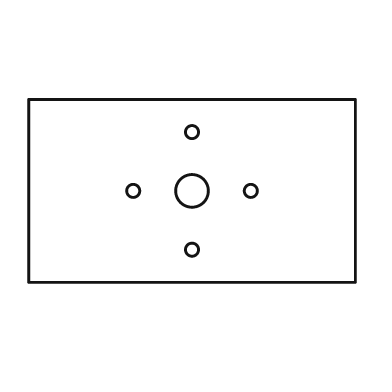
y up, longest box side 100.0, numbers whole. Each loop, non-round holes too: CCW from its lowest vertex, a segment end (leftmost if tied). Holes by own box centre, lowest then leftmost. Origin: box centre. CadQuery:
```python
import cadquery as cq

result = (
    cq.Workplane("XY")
    .moveTo(-50.0, -28.0)
    .lineTo(50.0, -28.0)
    .lineTo(50.0, 28.0)
    .lineTo(-50.0, 28.0)
    .close()
    .moveTo(0.0, -18.0)
    .circle(2.0)
    .moveTo(-18.0, 0.0)
    .circle(2.0)
    .moveTo(0.0, 0.0)
    .circle(5.0)
    .moveTo(18.0, 0.0)
    .circle(2.0)
    .moveTo(0.0, 18.0)
    .circle(2.0)
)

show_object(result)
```